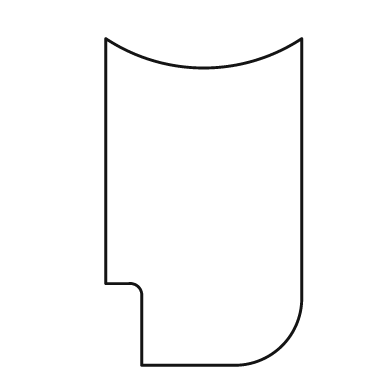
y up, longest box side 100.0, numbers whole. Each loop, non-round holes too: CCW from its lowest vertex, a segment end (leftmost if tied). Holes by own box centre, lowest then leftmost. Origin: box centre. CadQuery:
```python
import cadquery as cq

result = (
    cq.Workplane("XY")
    .moveTo(-19.0, -50.0)
    .lineTo(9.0, -50.0)
    .threePointArc((24.0, -44.0), (30.0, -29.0))
    .lineTo(30.0, 50.0)
    .threePointArc((0.0, 41.0), (-30.0, 50.0))
    .lineTo(-30.0, -25.0)
    .lineTo(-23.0, -25.0)
    .threePointArc((-20.0, -26.0), (-19.0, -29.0))
    .close()
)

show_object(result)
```